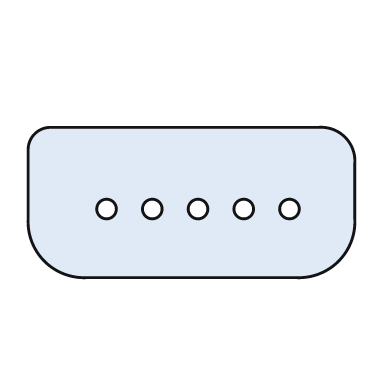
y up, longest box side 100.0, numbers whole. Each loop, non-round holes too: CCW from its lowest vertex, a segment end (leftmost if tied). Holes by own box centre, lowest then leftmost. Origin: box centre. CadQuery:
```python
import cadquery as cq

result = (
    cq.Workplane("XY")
    .moveTo(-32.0, -23.0)
    .lineTo(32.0, -23.0)
    .threePointArc((45.0, -18.0), (50.0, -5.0))
    .lineTo(50.0, 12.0)
    .threePointArc((47.0, 20.0), (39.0, 23.0))
    .lineTo(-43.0, 23.0)
    .threePointArc((-48.0, 21.0), (-50.0, 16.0))
    .lineTo(-50.0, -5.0)
    .threePointArc((-45.0, -18.0), (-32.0, -23.0))
    .close()
    .moveTo(-26.0, -2.0)
    .circle(3.0)
    .moveTo(-12.0, -2.0)
    .circle(3.0)
    .moveTo(2.0, -2.0)
    .circle(3.0)
    .moveTo(16.0, -2.0)
    .circle(3.0)
    .moveTo(30.0, -2.0)
    .circle(3.0)
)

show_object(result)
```